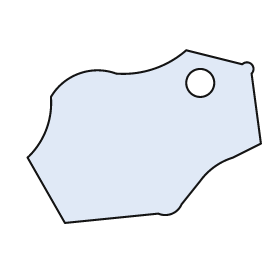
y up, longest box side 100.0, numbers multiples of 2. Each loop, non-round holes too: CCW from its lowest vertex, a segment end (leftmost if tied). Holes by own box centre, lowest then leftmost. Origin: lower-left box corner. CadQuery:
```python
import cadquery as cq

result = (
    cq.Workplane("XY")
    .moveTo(16.0, 0.0)
    .lineTo(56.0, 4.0)
    .threePointArc((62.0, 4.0), (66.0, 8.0))
    .lineTo(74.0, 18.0)
    .threePointArc((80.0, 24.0), (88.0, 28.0))
    .lineTo(100.0, 34.0)
    .lineTo(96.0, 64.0)
    .threePointArc((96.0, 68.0), (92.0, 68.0))
    .lineTo(68.0, 74.0)
    .threePointArc((54.0, 66.0), (38.0, 64.0))
    .threePointArc((22.0, 64.0), (10.0, 54.0))
    .threePointArc((8.0, 40.0), (0.0, 28.0))
    .close()
    .moveTo(74.0, 60.0)
    .circle(6.0)
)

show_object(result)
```